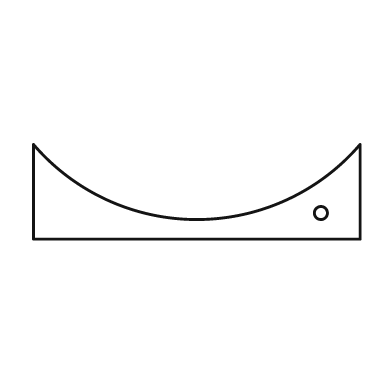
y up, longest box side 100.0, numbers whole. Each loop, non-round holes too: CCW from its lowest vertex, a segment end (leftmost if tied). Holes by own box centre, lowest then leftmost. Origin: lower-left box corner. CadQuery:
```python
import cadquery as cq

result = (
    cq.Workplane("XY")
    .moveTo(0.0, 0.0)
    .lineTo(100.0, 0.0)
    .lineTo(100.0, 29.0)
    .threePointArc((50.0, 6.0), (0.0, 29.0))
    .close()
    .moveTo(88.0, 8.0)
    .circle(2.0)
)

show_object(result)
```